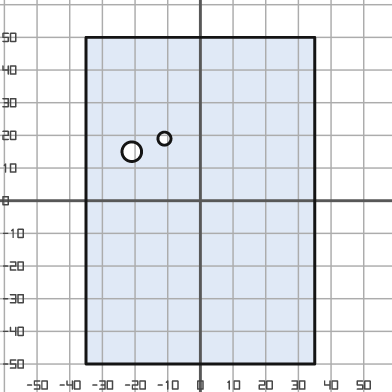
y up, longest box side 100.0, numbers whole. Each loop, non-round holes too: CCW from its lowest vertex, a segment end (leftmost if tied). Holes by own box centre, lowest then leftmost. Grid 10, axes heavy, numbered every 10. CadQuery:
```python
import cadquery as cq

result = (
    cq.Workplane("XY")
    .moveTo(-35.0, -50.0)
    .lineTo(35.0, -50.0)
    .lineTo(35.0, 50.0)
    .lineTo(-35.0, 50.0)
    .close()
    .moveTo(-21.0, 15.0)
    .circle(3.0)
    .moveTo(-11.0, 19.0)
    .circle(2.0)
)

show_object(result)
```